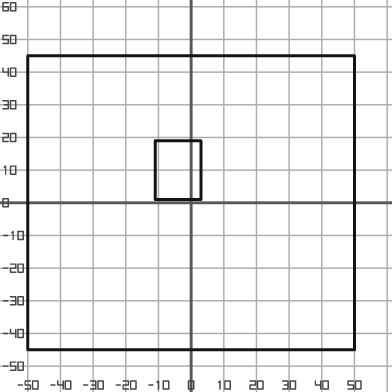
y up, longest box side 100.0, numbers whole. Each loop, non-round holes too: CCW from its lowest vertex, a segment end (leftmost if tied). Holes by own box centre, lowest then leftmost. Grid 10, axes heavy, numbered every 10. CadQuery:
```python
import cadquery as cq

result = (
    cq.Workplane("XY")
    .moveTo(-50.0, -45.0)
    .lineTo(50.0, -45.0)
    .lineTo(50.0, 45.0)
    .lineTo(-50.0, 45.0)
    .close()
    .moveTo(-11.0, 1.0)
    .lineTo(3.0, 1.0)
    .lineTo(3.0, 19.0)
    .lineTo(-11.0, 19.0)
    .close()
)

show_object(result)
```